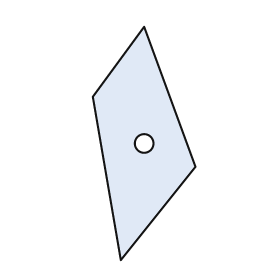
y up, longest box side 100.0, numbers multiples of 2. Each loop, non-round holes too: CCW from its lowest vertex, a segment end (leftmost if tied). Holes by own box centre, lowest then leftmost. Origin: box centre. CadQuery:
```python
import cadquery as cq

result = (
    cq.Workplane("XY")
    .moveTo(-10.0, -50.0)
    .lineTo(22.0, -10.0)
    .lineTo(0.0, 50.0)
    .lineTo(-22.0, 20.0)
    .close()
    .moveTo(0.0, 0.0)
    .circle(4.0)
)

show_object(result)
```